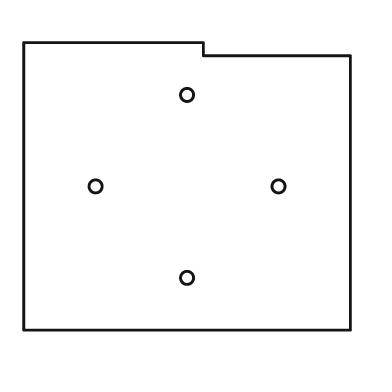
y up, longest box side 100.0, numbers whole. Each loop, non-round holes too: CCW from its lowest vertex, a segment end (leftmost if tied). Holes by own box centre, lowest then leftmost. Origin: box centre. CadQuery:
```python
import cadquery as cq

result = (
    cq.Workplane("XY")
    .moveTo(-50.0, -44.0)
    .lineTo(50.0, -44.0)
    .lineTo(50.0, 40.0)
    .lineTo(5.0, 40.0)
    .lineTo(5.0, 44.0)
    .lineTo(-50.0, 44.0)
    .close()
    .moveTo(0.0, -28.0)
    .circle(2.0)
    .moveTo(-28.0, 0.0)
    .circle(2.0)
    .moveTo(28.0, 0.0)
    .circle(2.0)
    .moveTo(0.0, 28.0)
    .circle(2.0)
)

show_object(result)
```